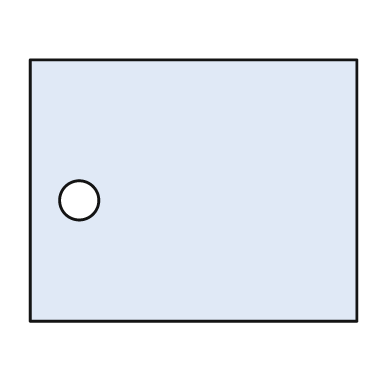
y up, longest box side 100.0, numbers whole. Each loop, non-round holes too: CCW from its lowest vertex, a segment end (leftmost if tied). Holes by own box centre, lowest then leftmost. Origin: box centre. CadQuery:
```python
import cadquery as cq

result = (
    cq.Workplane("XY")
    .moveTo(-50.0, -40.0)
    .lineTo(50.0, -40.0)
    .lineTo(50.0, 40.0)
    .lineTo(-50.0, 40.0)
    .close()
    .moveTo(-35.0, -3.0)
    .circle(6.0)
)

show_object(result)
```